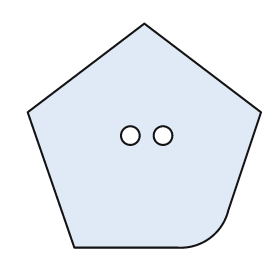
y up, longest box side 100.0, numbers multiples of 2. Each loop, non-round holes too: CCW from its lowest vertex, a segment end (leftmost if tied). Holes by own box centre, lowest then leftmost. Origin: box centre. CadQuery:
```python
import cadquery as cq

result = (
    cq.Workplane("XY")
    .moveTo(-30.0, -48.0)
    .lineTo(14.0, -48.0)
    .threePointArc((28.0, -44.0), (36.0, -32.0))
    .lineTo(50.0, 10.0)
    .lineTo(0.0, 48.0)
    .lineTo(-50.0, 10.0)
    .close()
    .moveTo(-6.0, 0.0)
    .circle(4.0)
    .moveTo(8.0, 0.0)
    .circle(4.0)
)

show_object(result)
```